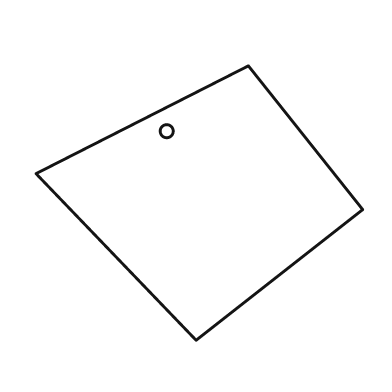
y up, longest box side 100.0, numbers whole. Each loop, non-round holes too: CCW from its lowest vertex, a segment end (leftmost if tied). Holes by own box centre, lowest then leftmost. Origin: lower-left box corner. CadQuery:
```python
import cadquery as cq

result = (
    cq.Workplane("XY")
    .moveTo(49.0, 0.0)
    .lineTo(100.0, 40.0)
    .lineTo(65.0, 84.0)
    .lineTo(0.0, 51.0)
    .close()
    .moveTo(40.0, 64.0)
    .circle(2.0)
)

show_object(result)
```